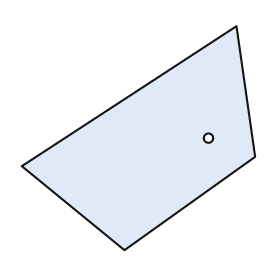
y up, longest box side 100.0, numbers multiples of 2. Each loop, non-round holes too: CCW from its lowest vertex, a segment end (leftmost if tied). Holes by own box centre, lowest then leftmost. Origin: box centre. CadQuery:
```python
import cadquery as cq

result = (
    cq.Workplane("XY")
    .moveTo(-6.0, -48.0)
    .lineTo(50.0, -8.0)
    .lineTo(42.0, 48.0)
    .lineTo(-50.0, -12.0)
    .close()
    .moveTo(30.0, 0.0)
    .circle(2.0)
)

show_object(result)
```